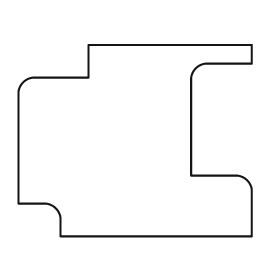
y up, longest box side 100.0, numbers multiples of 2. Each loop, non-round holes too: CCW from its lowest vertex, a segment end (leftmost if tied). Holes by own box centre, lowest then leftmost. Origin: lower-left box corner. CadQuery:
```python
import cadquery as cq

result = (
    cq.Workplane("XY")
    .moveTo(18.0, 0.0)
    .lineTo(100.0, 0.0)
    .lineTo(100.0, 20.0)
    .threePointArc((98.0, 24.0), (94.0, 26.0))
    .lineTo(74.0, 26.0)
    .lineTo(74.0, 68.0)
    .threePointArc((76.0, 72.0), (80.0, 74.0))
    .lineTo(100.0, 74.0)
    .lineTo(100.0, 82.0)
    .lineTo(30.0, 82.0)
    .lineTo(30.0, 68.0)
    .lineTo(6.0, 68.0)
    .threePointArc((2.0, 66.0), (0.0, 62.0))
    .lineTo(0.0, 14.0)
    .lineTo(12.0, 14.0)
    .threePointArc((16.0, 12.0), (18.0, 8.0))
    .close()
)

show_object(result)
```